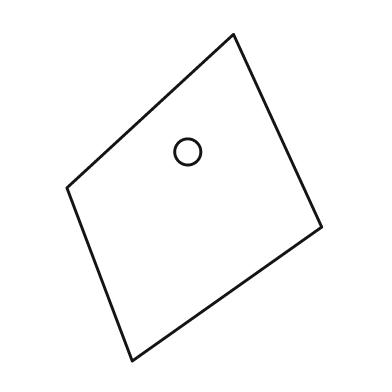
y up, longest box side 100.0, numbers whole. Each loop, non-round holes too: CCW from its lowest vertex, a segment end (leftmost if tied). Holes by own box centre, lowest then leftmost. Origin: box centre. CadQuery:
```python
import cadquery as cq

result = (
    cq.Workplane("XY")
    .moveTo(-19.0, -50.0)
    .lineTo(39.0, -9.0)
    .lineTo(12.0, 50.0)
    .lineTo(-39.0, 3.0)
    .close()
    .moveTo(-2.0, 14.0)
    .circle(4.0)
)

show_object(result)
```